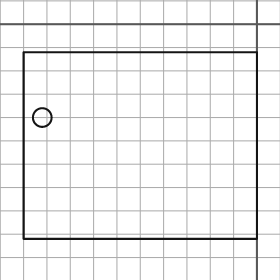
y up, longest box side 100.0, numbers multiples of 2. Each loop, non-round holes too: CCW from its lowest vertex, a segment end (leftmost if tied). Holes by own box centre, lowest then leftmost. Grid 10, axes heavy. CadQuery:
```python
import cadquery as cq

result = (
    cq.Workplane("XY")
    .moveTo(-100.0, -92.0)
    .lineTo(0.0, -92.0)
    .lineTo(0.0, -12.0)
    .lineTo(-100.0, -12.0)
    .close()
    .moveTo(-92.0, -40.0)
    .circle(4.0)
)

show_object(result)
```